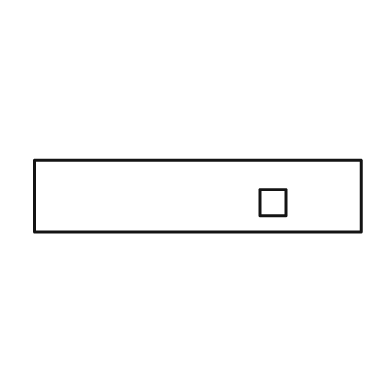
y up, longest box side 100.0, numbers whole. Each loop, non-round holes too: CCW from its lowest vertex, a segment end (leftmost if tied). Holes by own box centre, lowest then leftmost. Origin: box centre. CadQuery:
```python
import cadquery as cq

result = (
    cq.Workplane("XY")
    .moveTo(-50.0, -11.0)
    .lineTo(50.0, -11.0)
    .lineTo(50.0, 11.0)
    .lineTo(-50.0, 11.0)
    .close()
    .moveTo(19.0, -6.0)
    .lineTo(27.0, -6.0)
    .lineTo(27.0, 2.0)
    .lineTo(19.0, 2.0)
    .close()
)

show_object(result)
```